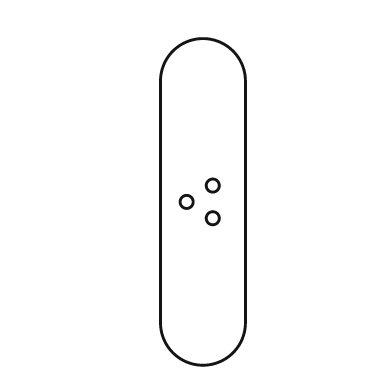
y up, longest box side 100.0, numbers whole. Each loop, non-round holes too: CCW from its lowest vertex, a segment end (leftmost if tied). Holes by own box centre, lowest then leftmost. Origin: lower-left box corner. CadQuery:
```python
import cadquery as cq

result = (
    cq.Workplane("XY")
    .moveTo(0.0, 13.0)
    .threePointArc((13.0, 0.0), (26.0, 13.0))
    .lineTo(26.0, 87.0)
    .threePointArc((13.0, 100.0), (0.0, 87.0))
    .close()
    .moveTo(16.0, 45.0)
    .circle(2.0)
    .moveTo(8.0, 50.0)
    .circle(2.0)
    .moveTo(16.0, 55.0)
    .circle(2.0)
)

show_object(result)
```